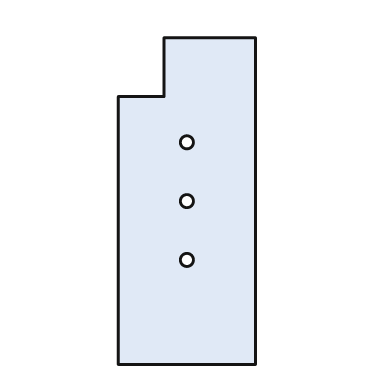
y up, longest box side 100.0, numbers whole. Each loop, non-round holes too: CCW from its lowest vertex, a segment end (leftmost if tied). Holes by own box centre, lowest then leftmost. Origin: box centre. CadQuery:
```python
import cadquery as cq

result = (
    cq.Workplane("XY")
    .moveTo(-21.0, -50.0)
    .lineTo(21.0, -50.0)
    .lineTo(21.0, 50.0)
    .lineTo(-7.0, 50.0)
    .lineTo(-7.0, 32.0)
    .lineTo(-21.0, 32.0)
    .close()
    .moveTo(0.0, -18.0)
    .circle(2.0)
    .moveTo(0.0, 0.0)
    .circle(2.0)
    .moveTo(0.0, 18.0)
    .circle(2.0)
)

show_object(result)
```